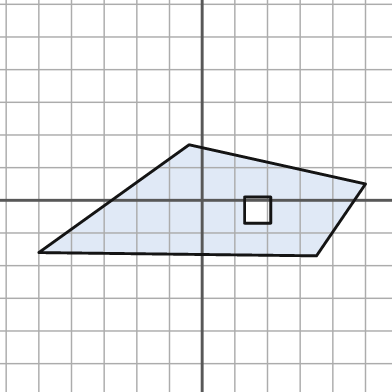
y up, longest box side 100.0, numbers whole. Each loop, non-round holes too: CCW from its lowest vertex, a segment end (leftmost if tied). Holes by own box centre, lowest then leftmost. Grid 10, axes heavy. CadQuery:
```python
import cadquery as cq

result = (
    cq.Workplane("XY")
    .moveTo(35.0, -17.0)
    .lineTo(50.0, 5.0)
    .lineTo(-4.0, 17.0)
    .lineTo(-50.0, -16.0)
    .close()
    .moveTo(13.0, -7.0)
    .lineTo(21.0, -7.0)
    .lineTo(21.0, 1.0)
    .lineTo(13.0, 1.0)
    .close()
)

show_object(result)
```